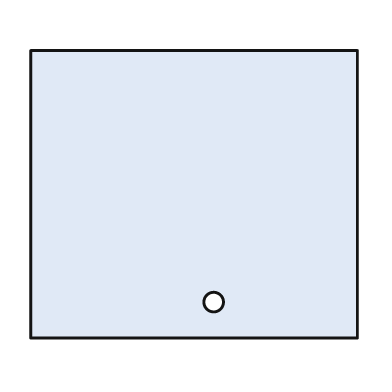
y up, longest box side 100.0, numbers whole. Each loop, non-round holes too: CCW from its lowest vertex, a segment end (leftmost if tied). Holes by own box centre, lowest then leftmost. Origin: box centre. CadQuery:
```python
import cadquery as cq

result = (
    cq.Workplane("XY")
    .moveTo(-50.0, -44.0)
    .lineTo(50.0, -44.0)
    .lineTo(50.0, 44.0)
    .lineTo(-50.0, 44.0)
    .close()
    .moveTo(6.0, -33.0)
    .circle(3.0)
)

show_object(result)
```